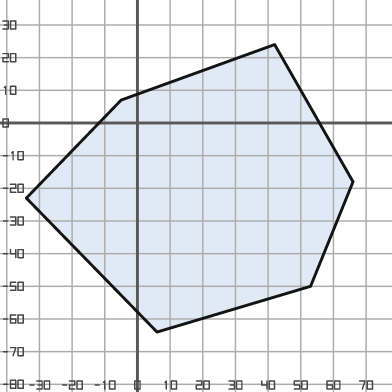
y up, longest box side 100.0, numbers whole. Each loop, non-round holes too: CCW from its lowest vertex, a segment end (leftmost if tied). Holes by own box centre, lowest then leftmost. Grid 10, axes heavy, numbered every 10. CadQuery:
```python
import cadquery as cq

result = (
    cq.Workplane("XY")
    .moveTo(6.0, -64.0)
    .lineTo(53.0, -50.0)
    .lineTo(66.0, -18.0)
    .lineTo(42.0, 24.0)
    .lineTo(-5.0, 7.0)
    .lineTo(-34.0, -23.0)
    .close()
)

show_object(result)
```